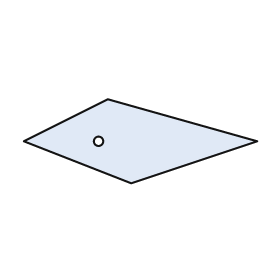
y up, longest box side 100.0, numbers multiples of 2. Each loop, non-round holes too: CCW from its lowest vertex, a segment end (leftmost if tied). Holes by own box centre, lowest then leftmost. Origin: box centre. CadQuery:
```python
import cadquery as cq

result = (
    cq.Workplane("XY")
    .moveTo(-4.0, -18.0)
    .lineTo(50.0, 0.0)
    .lineTo(-14.0, 18.0)
    .lineTo(-50.0, 0.0)
    .close()
    .moveTo(-18.0, 0.0)
    .circle(2.0)
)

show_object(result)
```